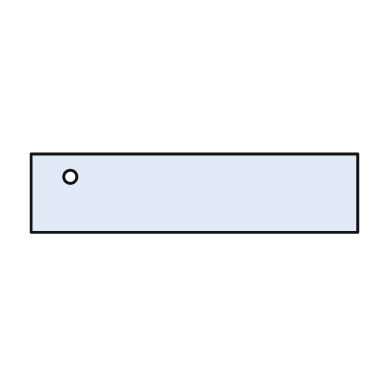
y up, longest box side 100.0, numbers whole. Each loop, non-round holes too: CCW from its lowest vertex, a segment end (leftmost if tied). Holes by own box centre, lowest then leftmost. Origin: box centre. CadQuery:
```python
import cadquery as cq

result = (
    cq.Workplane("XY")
    .moveTo(-50.0, -12.0)
    .lineTo(50.0, -12.0)
    .lineTo(50.0, 12.0)
    .lineTo(-50.0, 12.0)
    .close()
    .moveTo(-38.0, 5.0)
    .circle(2.0)
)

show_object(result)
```